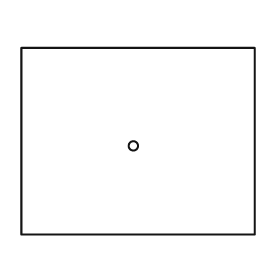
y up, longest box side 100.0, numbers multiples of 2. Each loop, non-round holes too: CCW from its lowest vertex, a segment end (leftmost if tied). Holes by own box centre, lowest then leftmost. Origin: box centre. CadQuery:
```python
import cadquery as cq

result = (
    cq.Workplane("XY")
    .moveTo(-50.0, -40.0)
    .lineTo(50.0, -40.0)
    .lineTo(50.0, 40.0)
    .lineTo(-50.0, 40.0)
    .close()
    .moveTo(-2.0, -2.0)
    .circle(2.0)
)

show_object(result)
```